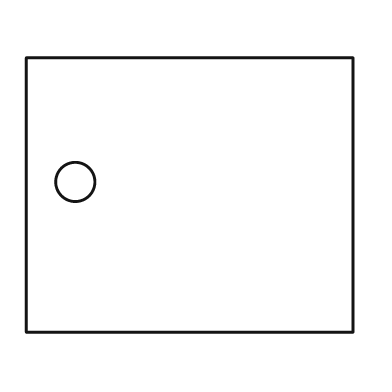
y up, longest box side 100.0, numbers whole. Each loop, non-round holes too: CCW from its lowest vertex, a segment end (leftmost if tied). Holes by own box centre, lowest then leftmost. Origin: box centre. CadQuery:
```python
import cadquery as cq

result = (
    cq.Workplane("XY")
    .moveTo(-50.0, -42.0)
    .lineTo(50.0, -42.0)
    .lineTo(50.0, 42.0)
    .lineTo(-50.0, 42.0)
    .close()
    .moveTo(-35.0, 4.0)
    .circle(6.0)
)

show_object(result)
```